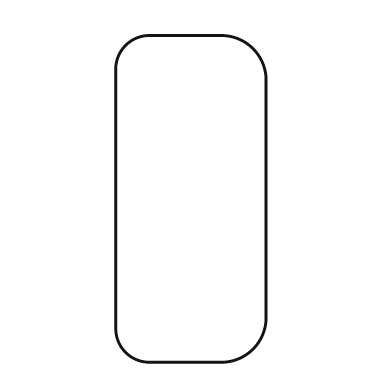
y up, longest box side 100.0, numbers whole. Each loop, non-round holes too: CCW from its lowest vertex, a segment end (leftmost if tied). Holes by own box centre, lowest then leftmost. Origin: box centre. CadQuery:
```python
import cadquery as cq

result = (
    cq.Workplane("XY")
    .moveTo(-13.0, -50.0)
    .lineTo(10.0, -50.0)
    .threePointArc((19.0, -46.0), (23.0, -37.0))
    .lineTo(23.0, 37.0)
    .threePointArc((19.0, 46.0), (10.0, 50.0))
    .lineTo(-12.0, 50.0)
    .threePointArc((-20.0, 47.0), (-23.0, 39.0))
    .lineTo(-23.0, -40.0)
    .threePointArc((-20.0, -47.0), (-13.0, -50.0))
    .close()
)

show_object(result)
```